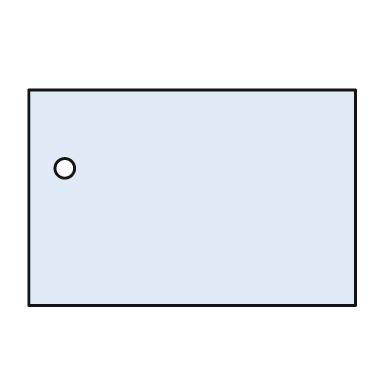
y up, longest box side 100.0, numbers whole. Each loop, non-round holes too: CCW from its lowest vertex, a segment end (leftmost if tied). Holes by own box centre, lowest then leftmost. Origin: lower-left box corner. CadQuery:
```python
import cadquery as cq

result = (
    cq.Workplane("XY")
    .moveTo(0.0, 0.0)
    .lineTo(100.0, 0.0)
    .lineTo(100.0, 66.0)
    .lineTo(0.0, 66.0)
    .close()
    .moveTo(11.0, 42.0)
    .circle(3.0)
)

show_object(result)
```